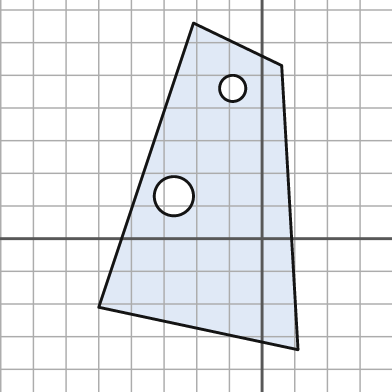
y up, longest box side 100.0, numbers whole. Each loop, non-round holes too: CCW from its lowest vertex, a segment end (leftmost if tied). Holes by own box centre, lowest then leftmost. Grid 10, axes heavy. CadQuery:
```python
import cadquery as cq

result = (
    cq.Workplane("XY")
    .moveTo(11.0, -34.0)
    .lineTo(6.0, 53.0)
    .lineTo(-21.0, 66.0)
    .lineTo(-50.0, -21.0)
    .close()
    .moveTo(-27.0, 13.0)
    .circle(6.0)
    .moveTo(-9.0, 46.0)
    .circle(4.0)
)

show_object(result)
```